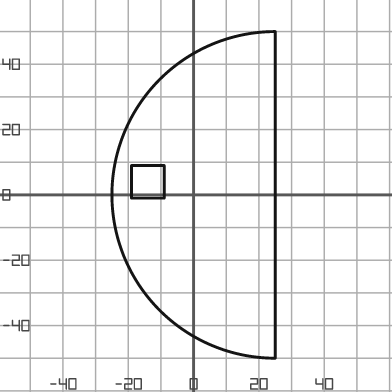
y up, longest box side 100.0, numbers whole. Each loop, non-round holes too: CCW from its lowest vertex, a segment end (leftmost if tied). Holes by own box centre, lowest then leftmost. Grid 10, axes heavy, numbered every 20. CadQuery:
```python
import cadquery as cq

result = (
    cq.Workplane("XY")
    .moveTo(25.0, -50.0)
    .lineTo(25.0, 50.0)
    .threePointArc((-25.0, 0.0), (25.0, -50.0))
    .close()
    .moveTo(-19.0, -1.0)
    .lineTo(-9.0, -1.0)
    .lineTo(-9.0, 9.0)
    .lineTo(-19.0, 9.0)
    .close()
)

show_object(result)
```